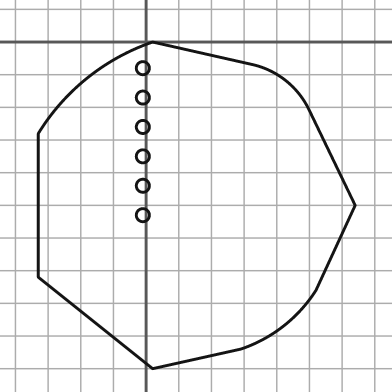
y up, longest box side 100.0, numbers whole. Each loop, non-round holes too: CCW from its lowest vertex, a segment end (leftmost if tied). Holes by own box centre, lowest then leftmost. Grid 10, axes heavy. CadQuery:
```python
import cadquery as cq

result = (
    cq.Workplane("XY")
    .moveTo(2.0, -100.0)
    .lineTo(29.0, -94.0)
    .threePointArc((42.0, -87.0), (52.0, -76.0))
    .lineTo(64.0, -50.0)
    .lineTo(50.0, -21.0)
    .threePointArc((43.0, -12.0), (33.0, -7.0))
    .lineTo(2.0, 0.0)
    .threePointArc((-18.0, -11.0), (-33.0, -28.0))
    .lineTo(-33.0, -72.0)
    .close()
    .moveTo(-1.0, -53.0)
    .circle(2.0)
    .moveTo(-1.0, -44.0)
    .circle(2.0)
    .moveTo(-1.0, -35.0)
    .circle(2.0)
    .moveTo(-1.0, -26.0)
    .circle(2.0)
    .moveTo(-1.0, -17.0)
    .circle(2.0)
    .moveTo(-1.0, -8.0)
    .circle(2.0)
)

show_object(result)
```